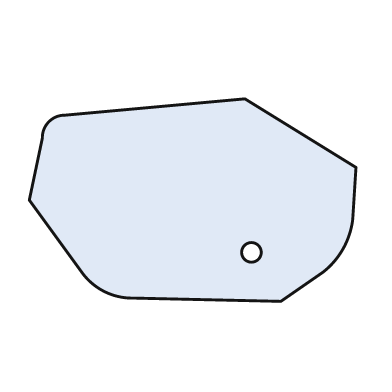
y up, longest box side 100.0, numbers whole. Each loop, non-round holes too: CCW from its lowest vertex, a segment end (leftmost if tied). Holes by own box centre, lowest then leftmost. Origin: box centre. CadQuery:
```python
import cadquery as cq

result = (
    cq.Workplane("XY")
    .moveTo(27.0, -31.0)
    .lineTo(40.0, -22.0)
    .threePointArc((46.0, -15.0), (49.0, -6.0))
    .lineTo(50.0, 10.0)
    .lineTo(16.0, 31.0)
    .lineTo(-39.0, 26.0)
    .threePointArc((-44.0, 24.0), (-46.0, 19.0))
    .lineTo(-50.0, 0.0)
    .lineTo(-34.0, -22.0)
    .threePointArc((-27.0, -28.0), (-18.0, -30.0))
    .close()
    .moveTo(18.0, -16.0)
    .circle(3.0)
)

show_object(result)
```